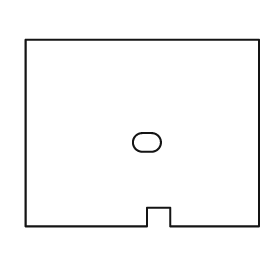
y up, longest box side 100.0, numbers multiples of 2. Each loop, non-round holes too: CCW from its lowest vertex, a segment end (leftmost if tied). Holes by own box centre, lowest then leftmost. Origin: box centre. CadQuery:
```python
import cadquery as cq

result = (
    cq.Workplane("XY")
    .moveTo(-50.0, -40.0)
    .lineTo(2.0, -40.0)
    .lineTo(2.0, -32.0)
    .lineTo(12.0, -32.0)
    .lineTo(12.0, -40.0)
    .lineTo(50.0, -40.0)
    .lineTo(50.0, 40.0)
    .lineTo(-50.0, 40.0)
    .close()
    .moveTo(0.0, -8.0)
    .lineTo(4.0, -8.0)
    .threePointArc((8.0, -4.0), (4.0, 0.0))
    .lineTo(0.0, 0.0)
    .threePointArc((-4.0, -4.0), (0.0, -8.0))
    .close()
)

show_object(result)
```